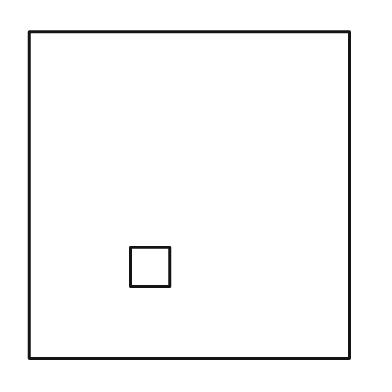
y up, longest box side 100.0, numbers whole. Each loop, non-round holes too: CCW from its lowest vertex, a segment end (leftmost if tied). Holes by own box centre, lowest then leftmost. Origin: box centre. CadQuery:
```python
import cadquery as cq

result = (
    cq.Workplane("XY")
    .moveTo(-49.0, -50.0)
    .lineTo(49.0, -50.0)
    .lineTo(49.0, 50.0)
    .lineTo(-49.0, 50.0)
    .close()
    .moveTo(-18.0, -28.0)
    .lineTo(-6.0, -28.0)
    .lineTo(-6.0, -16.0)
    .lineTo(-18.0, -16.0)
    .close()
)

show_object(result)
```